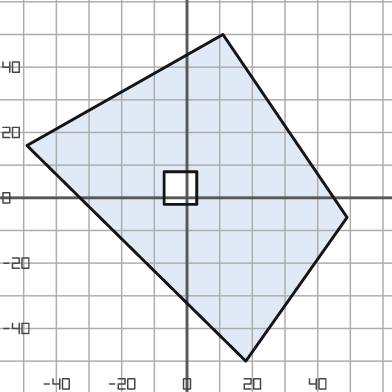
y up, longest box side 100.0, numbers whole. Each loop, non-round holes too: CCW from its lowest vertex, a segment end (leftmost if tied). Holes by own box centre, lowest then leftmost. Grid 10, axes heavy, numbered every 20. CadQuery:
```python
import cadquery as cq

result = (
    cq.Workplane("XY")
    .moveTo(18.0, -50.0)
    .lineTo(49.0, -6.0)
    .lineTo(11.0, 50.0)
    .lineTo(-49.0, 16.0)
    .close()
    .moveTo(-7.0, -2.0)
    .lineTo(3.0, -2.0)
    .lineTo(3.0, 8.0)
    .lineTo(-7.0, 8.0)
    .close()
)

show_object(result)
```